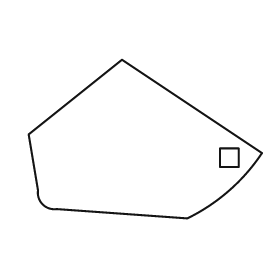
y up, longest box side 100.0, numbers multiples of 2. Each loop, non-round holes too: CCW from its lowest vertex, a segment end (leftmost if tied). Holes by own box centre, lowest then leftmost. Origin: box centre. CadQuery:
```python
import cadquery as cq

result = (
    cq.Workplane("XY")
    .moveTo(18.0, -34.0)
    .threePointArc((36.0, -22.0), (50.0, -6.0))
    .lineTo(-10.0, 34.0)
    .lineTo(-50.0, 2.0)
    .lineTo(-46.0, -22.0)
    .threePointArc((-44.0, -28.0), (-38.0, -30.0))
    .close()
    .moveTo(32.0, -12.0)
    .lineTo(40.0, -12.0)
    .lineTo(40.0, -4.0)
    .lineTo(32.0, -4.0)
    .close()
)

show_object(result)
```